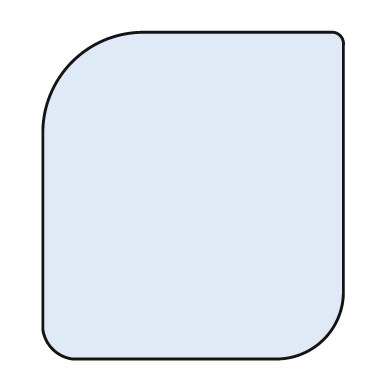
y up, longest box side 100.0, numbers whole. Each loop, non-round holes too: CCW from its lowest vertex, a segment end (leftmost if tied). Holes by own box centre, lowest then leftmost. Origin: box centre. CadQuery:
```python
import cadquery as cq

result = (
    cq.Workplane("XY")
    .moveTo(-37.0, -50.0)
    .lineTo(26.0, -50.0)
    .threePointArc((40.0, -44.0), (46.0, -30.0))
    .lineTo(46.0, 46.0)
    .threePointArc((45.0, 49.0), (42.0, 50.0))
    .lineTo(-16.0, 50.0)
    .threePointArc((-37.0, 41.0), (-46.0, 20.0))
    .lineTo(-46.0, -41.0)
    .threePointArc((-43.0, -47.0), (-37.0, -50.0))
    .close()
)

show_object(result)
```